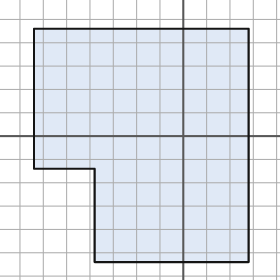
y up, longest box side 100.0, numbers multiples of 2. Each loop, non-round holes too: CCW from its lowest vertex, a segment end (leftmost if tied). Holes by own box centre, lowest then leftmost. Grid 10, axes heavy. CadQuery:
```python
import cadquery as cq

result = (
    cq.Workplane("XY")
    .moveTo(-38.0, -54.0)
    .lineTo(28.0, -54.0)
    .lineTo(28.0, 46.0)
    .lineTo(-64.0, 46.0)
    .lineTo(-64.0, -14.0)
    .lineTo(-38.0, -14.0)
    .close()
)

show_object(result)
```